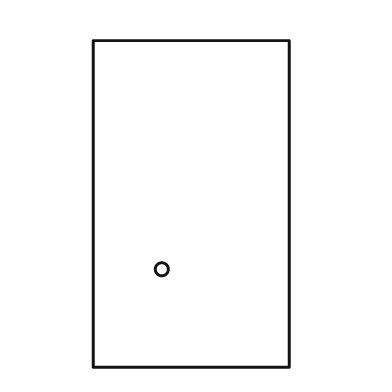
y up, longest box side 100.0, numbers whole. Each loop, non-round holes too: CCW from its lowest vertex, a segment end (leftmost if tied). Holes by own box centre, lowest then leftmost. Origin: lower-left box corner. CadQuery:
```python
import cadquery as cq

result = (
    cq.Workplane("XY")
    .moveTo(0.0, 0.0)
    .lineTo(60.0, 0.0)
    .lineTo(60.0, 100.0)
    .lineTo(0.0, 100.0)
    .close()
    .moveTo(21.0, 30.0)
    .circle(2.0)
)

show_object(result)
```